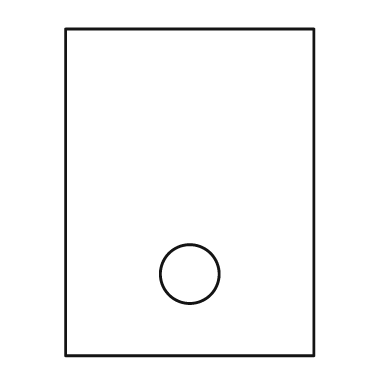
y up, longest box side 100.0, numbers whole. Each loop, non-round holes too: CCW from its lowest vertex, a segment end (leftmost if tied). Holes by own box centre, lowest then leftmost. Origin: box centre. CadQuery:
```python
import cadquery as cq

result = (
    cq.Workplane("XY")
    .moveTo(-38.0, -50.0)
    .lineTo(38.0, -50.0)
    .lineTo(38.0, 50.0)
    .lineTo(-38.0, 50.0)
    .close()
    .moveTo(0.0, -25.0)
    .circle(9.0)
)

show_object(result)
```